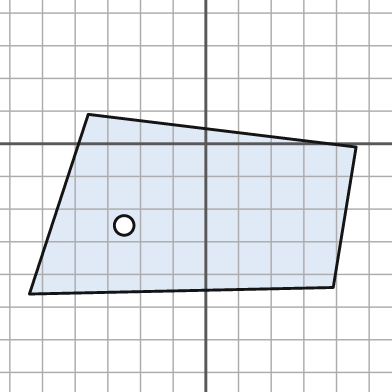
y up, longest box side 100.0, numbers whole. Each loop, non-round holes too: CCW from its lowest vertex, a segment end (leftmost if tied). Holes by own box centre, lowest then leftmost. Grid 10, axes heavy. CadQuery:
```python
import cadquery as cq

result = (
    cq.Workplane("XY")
    .moveTo(-54.0, -46.0)
    .lineTo(39.0, -44.0)
    .lineTo(46.0, -1.0)
    .lineTo(-36.0, 9.0)
    .close()
    .moveTo(-25.0, -25.0)
    .circle(3.0)
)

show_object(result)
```